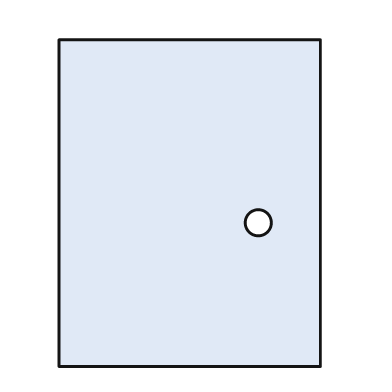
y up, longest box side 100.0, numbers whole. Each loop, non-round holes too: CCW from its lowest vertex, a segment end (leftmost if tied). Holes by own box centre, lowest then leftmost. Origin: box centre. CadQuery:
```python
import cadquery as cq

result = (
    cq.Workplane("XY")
    .moveTo(-40.0, -50.0)
    .lineTo(40.0, -50.0)
    .lineTo(40.0, 50.0)
    .lineTo(-40.0, 50.0)
    .close()
    .moveTo(21.0, -6.0)
    .circle(4.0)
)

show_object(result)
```